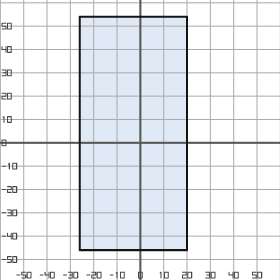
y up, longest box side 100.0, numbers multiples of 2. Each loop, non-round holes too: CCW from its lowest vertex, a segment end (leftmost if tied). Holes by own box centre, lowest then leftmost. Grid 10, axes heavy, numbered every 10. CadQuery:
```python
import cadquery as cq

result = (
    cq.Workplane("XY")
    .moveTo(-26.0, -46.0)
    .lineTo(20.0, -46.0)
    .lineTo(20.0, 54.0)
    .lineTo(-26.0, 54.0)
    .close()
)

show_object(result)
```